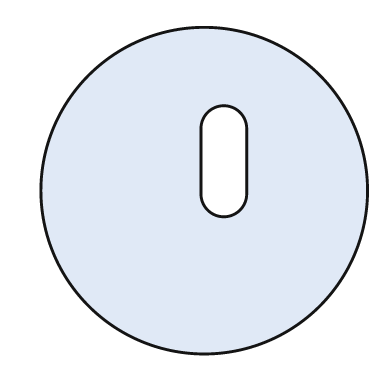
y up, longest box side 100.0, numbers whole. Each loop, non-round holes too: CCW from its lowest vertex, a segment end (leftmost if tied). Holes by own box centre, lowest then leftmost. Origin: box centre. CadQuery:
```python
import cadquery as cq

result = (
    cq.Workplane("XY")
    .moveTo(0.0, 0.0)
    .circle(50.0)
    .moveTo(-1.0, -1.0)
    .threePointArc((6.0, -8.0), (13.0, -1.0))
    .lineTo(13.0, 19.0)
    .threePointArc((6.0, 26.0), (-1.0, 19.0))
    .close()
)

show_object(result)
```